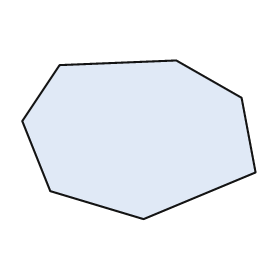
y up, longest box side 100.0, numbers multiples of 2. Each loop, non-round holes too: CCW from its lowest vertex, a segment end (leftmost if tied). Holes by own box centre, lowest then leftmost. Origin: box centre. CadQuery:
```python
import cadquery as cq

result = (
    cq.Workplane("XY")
    .moveTo(2.0, -34.0)
    .lineTo(50.0, -14.0)
    .lineTo(44.0, 18.0)
    .lineTo(16.0, 34.0)
    .lineTo(-34.0, 32.0)
    .lineTo(-50.0, 8.0)
    .lineTo(-38.0, -22.0)
    .close()
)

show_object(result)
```